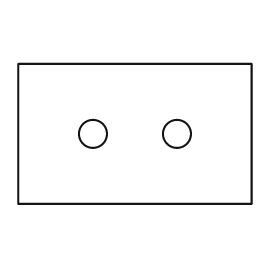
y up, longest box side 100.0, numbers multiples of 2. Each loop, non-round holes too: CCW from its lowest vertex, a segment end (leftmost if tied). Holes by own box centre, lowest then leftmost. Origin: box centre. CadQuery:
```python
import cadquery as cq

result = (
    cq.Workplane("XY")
    .moveTo(-50.0, -30.0)
    .lineTo(50.0, -30.0)
    .lineTo(50.0, 30.0)
    .lineTo(-50.0, 30.0)
    .close()
    .moveTo(-18.0, 0.0)
    .circle(6.0)
    .moveTo(18.0, 0.0)
    .circle(6.0)
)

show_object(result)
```